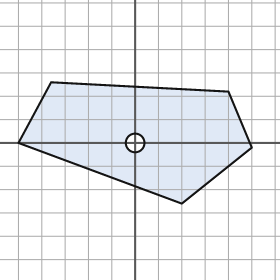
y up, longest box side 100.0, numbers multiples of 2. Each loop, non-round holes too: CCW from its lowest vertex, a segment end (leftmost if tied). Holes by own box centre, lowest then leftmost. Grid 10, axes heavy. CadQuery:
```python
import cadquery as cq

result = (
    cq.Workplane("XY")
    .moveTo(20.0, -26.0)
    .lineTo(50.0, -2.0)
    .lineTo(40.0, 22.0)
    .lineTo(-36.0, 26.0)
    .lineTo(-50.0, 0.0)
    .close()
    .moveTo(0.0, 0.0)
    .circle(4.0)
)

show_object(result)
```